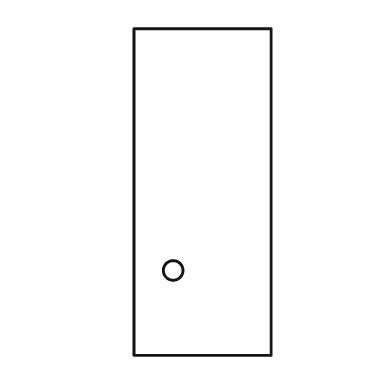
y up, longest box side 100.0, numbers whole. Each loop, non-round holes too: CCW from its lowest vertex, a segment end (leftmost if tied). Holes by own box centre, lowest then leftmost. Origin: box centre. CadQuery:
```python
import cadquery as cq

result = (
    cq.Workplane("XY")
    .moveTo(-21.0, -50.0)
    .lineTo(21.0, -50.0)
    .lineTo(21.0, 50.0)
    .lineTo(-21.0, 50.0)
    .close()
    .moveTo(-9.0, -24.0)
    .circle(3.0)
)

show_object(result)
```